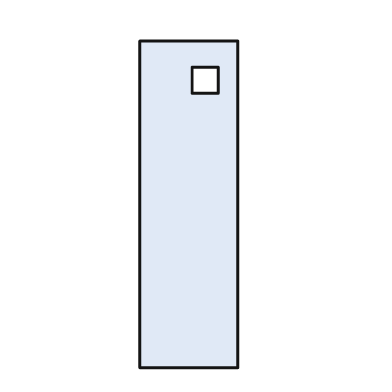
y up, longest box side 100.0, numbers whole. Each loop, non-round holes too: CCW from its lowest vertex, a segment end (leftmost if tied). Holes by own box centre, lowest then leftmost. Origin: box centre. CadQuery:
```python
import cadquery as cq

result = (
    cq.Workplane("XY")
    .moveTo(-15.0, -50.0)
    .lineTo(15.0, -50.0)
    .lineTo(15.0, 50.0)
    .lineTo(-15.0, 50.0)
    .close()
    .moveTo(1.0, 34.0)
    .lineTo(9.0, 34.0)
    .lineTo(9.0, 42.0)
    .lineTo(1.0, 42.0)
    .close()
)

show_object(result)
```